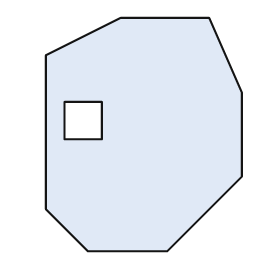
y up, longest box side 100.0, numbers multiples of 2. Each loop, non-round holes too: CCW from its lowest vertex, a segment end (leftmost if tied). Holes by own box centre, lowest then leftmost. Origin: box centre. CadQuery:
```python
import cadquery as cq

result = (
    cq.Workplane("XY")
    .moveTo(-24.0, -50.0)
    .lineTo(10.0, -50.0)
    .lineTo(42.0, -18.0)
    .lineTo(42.0, 18.0)
    .lineTo(28.0, 50.0)
    .lineTo(-10.0, 50.0)
    .lineTo(-42.0, 34.0)
    .lineTo(-42.0, -32.0)
    .close()
    .moveTo(-34.0, -2.0)
    .lineTo(-18.0, -2.0)
    .lineTo(-18.0, 14.0)
    .lineTo(-34.0, 14.0)
    .close()
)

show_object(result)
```